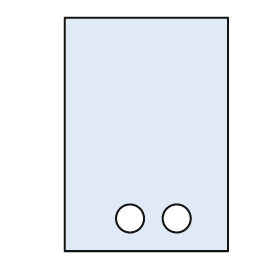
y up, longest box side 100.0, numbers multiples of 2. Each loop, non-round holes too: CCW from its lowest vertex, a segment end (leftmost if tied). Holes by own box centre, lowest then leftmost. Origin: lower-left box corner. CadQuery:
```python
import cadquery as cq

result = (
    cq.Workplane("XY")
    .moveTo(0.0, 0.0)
    .lineTo(70.0, 0.0)
    .lineTo(70.0, 100.0)
    .lineTo(0.0, 100.0)
    .close()
    .moveTo(28.0, 14.0)
    .circle(6.0)
    .moveTo(48.0, 14.0)
    .circle(6.0)
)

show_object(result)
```